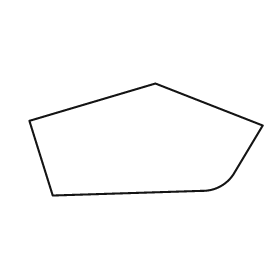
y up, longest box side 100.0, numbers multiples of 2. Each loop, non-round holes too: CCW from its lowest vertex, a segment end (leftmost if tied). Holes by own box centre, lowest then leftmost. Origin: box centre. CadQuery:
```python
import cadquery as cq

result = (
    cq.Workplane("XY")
    .moveTo(-40.0, -24.0)
    .lineTo(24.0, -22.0)
    .threePointArc((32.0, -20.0), (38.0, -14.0))
    .lineTo(50.0, 6.0)
    .lineTo(4.0, 24.0)
    .lineTo(-50.0, 8.0)
    .close()
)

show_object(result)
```